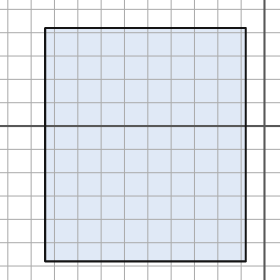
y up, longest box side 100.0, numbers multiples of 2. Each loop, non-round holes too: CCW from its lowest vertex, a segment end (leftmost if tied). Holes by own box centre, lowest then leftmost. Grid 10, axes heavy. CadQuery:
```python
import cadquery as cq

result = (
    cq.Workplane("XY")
    .moveTo(-94.0, -58.0)
    .lineTo(-8.0, -58.0)
    .lineTo(-8.0, 42.0)
    .lineTo(-94.0, 42.0)
    .close()
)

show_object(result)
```